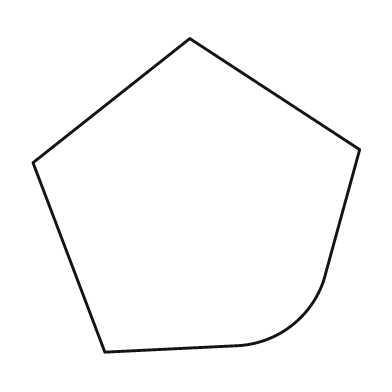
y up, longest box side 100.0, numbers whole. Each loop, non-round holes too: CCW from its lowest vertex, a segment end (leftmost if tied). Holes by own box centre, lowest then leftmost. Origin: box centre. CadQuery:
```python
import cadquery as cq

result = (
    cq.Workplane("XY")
    .moveTo(-28.0, -48.0)
    .lineTo(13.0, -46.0)
    .threePointArc((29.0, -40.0), (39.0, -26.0))
    .lineTo(50.0, 14.0)
    .lineTo(-2.0, 48.0)
    .lineTo(-50.0, 10.0)
    .close()
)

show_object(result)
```